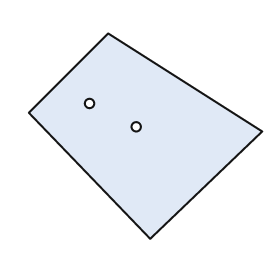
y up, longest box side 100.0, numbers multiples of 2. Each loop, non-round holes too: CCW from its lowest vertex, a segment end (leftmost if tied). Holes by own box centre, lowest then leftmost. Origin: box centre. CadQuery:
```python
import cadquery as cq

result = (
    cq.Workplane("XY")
    .moveTo(2.0, -44.0)
    .lineTo(50.0, 2.0)
    .lineTo(-16.0, 44.0)
    .lineTo(-50.0, 10.0)
    .close()
    .moveTo(-4.0, 4.0)
    .circle(2.0)
    .moveTo(-24.0, 14.0)
    .circle(2.0)
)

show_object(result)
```